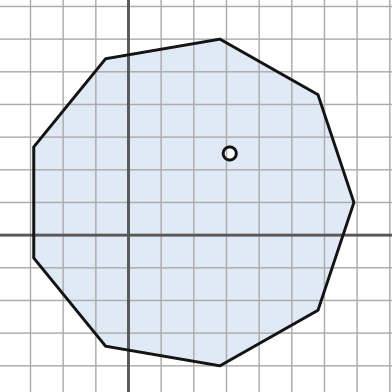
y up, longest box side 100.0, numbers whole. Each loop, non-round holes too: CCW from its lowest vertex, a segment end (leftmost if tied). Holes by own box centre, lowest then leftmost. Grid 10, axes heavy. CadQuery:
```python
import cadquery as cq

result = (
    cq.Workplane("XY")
    .moveTo(28.0, -40.0)
    .lineTo(58.0, -23.0)
    .lineTo(69.0, 10.0)
    .lineTo(58.0, 43.0)
    .lineTo(28.0, 60.0)
    .lineTo(-7.0, 54.0)
    .lineTo(-29.0, 27.0)
    .lineTo(-29.0, -7.0)
    .lineTo(-7.0, -34.0)
    .close()
    .moveTo(31.0, 25.0)
    .circle(2.0)
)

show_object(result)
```